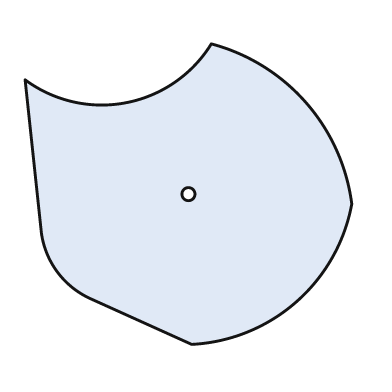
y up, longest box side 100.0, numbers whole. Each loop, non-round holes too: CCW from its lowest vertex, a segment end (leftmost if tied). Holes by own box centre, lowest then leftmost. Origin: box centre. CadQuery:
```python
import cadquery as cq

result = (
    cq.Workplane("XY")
    .moveTo(1.0, -46.0)
    .threePointArc((33.0, -33.0), (50.0, -3.0))
    .threePointArc((36.0, 28.0), (7.0, 46.0))
    .threePointArc((-19.0, 28.0), (-50.0, 35.0))
    .lineTo(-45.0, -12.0)
    .threePointArc((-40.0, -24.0), (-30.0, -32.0))
    .close()
    .moveTo(0.0, 0.0)
    .circle(2.0)
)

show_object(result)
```